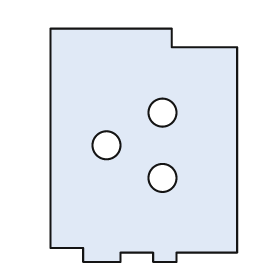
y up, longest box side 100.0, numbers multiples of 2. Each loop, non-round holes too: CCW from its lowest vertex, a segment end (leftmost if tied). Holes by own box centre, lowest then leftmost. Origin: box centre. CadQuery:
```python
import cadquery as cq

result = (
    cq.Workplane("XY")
    .moveTo(-26.0, -50.0)
    .lineTo(-10.0, -50.0)
    .lineTo(-10.0, -46.0)
    .lineTo(4.0, -46.0)
    .lineTo(4.0, -50.0)
    .lineTo(14.0, -50.0)
    .lineTo(14.0, -46.0)
    .lineTo(40.0, -46.0)
    .lineTo(40.0, 42.0)
    .lineTo(12.0, 42.0)
    .lineTo(12.0, 50.0)
    .lineTo(-40.0, 50.0)
    .lineTo(-40.0, -44.0)
    .lineTo(-26.0, -44.0)
    .close()
    .moveTo(8.0, -14.0)
    .circle(6.0)
    .moveTo(-16.0, 0.0)
    .circle(6.0)
    .moveTo(8.0, 14.0)
    .circle(6.0)
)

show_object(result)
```